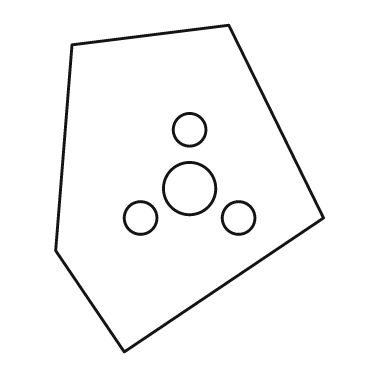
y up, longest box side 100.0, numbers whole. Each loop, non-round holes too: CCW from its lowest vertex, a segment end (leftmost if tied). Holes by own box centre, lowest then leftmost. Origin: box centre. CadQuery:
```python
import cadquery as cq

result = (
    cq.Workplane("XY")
    .moveTo(-20.0, -50.0)
    .lineTo(41.0, -9.0)
    .lineTo(12.0, 50.0)
    .lineTo(-36.0, 44.0)
    .lineTo(-41.0, -19.0)
    .close()
    .moveTo(-15.0, -9.0)
    .circle(5.0)
    .moveTo(15.0, -9.0)
    .circle(5.0)
    .moveTo(0.0, 0.0)
    .circle(8.0)
    .moveTo(0.0, 18.0)
    .circle(5.0)
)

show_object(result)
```